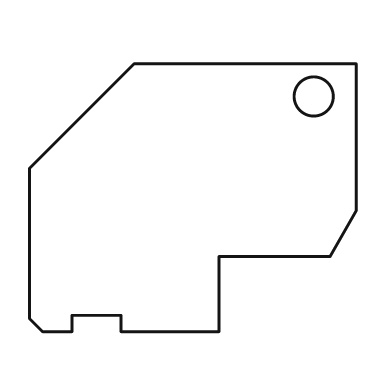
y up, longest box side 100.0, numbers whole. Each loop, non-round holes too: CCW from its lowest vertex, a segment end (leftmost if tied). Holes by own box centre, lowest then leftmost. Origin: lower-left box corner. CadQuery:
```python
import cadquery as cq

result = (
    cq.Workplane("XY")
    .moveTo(4.0, 0.0)
    .lineTo(13.0, 0.0)
    .lineTo(13.0, 5.0)
    .lineTo(28.0, 5.0)
    .lineTo(28.0, 0.0)
    .lineTo(58.0, 0.0)
    .lineTo(58.0, 23.0)
    .lineTo(92.0, 23.0)
    .lineTo(100.0, 37.0)
    .lineTo(100.0, 82.0)
    .lineTo(32.0, 82.0)
    .lineTo(0.0, 50.0)
    .lineTo(0.0, 4.0)
    .close()
    .moveTo(87.0, 72.0)
    .circle(6.0)
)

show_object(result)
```